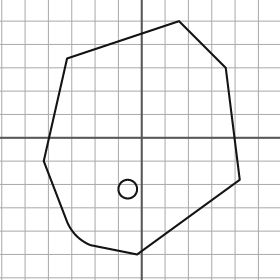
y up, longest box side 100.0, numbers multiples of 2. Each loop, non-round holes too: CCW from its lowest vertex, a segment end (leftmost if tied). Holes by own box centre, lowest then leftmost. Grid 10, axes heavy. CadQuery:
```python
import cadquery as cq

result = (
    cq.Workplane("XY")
    .moveTo(-2.0, -50.0)
    .lineTo(42.0, -18.0)
    .lineTo(36.0, 30.0)
    .lineTo(16.0, 50.0)
    .lineTo(-32.0, 34.0)
    .lineTo(-42.0, -10.0)
    .lineTo(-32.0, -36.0)
    .threePointArc((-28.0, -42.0), (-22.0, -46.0))
    .close()
    .moveTo(-6.0, -22.0)
    .circle(4.0)
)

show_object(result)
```